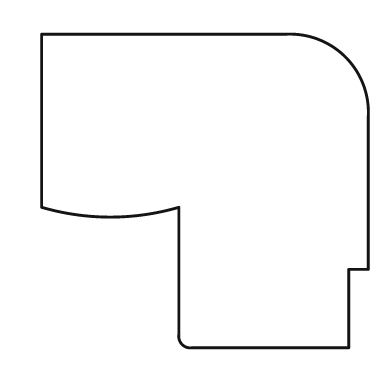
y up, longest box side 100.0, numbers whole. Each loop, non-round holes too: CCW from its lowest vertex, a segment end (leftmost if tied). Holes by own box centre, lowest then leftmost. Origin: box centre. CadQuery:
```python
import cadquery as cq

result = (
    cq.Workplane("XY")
    .moveTo(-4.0, -48.0)
    .lineTo(44.0, -48.0)
    .lineTo(44.0, -24.0)
    .lineTo(50.0, -24.0)
    .lineTo(50.0, 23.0)
    .threePointArc((43.0, 41.0), (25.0, 48.0))
    .lineTo(-50.0, 48.0)
    .lineTo(-50.0, -5.0)
    .threePointArc((-29.0, -8.0), (-8.0, -5.0))
    .lineTo(-8.0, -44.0)
    .threePointArc((-7.0, -47.0), (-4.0, -48.0))
    .close()
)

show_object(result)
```